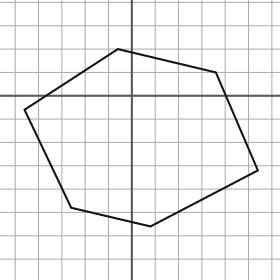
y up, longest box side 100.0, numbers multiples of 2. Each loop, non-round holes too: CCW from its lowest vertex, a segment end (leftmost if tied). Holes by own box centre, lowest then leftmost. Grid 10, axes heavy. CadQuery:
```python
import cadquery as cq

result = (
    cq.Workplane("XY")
    .moveTo(8.0, -56.0)
    .lineTo(54.0, -32.0)
    .lineTo(36.0, 10.0)
    .lineTo(-6.0, 20.0)
    .lineTo(-46.0, -6.0)
    .lineTo(-26.0, -48.0)
    .close()
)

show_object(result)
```